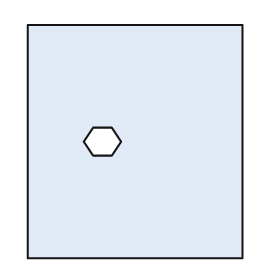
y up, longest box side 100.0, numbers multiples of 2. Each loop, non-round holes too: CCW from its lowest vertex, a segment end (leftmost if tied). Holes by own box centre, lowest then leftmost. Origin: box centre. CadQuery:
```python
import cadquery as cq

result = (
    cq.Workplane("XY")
    .moveTo(-46.0, -50.0)
    .lineTo(46.0, -50.0)
    .lineTo(46.0, 50.0)
    .lineTo(-46.0, 50.0)
    .close()
    .moveTo(-18.0, -6.0)
    .lineTo(-10.0, -6.0)
    .lineTo(-6.0, 0.0)
    .lineTo(-10.0, 6.0)
    .lineTo(-18.0, 6.0)
    .lineTo(-22.0, 0.0)
    .close()
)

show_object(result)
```